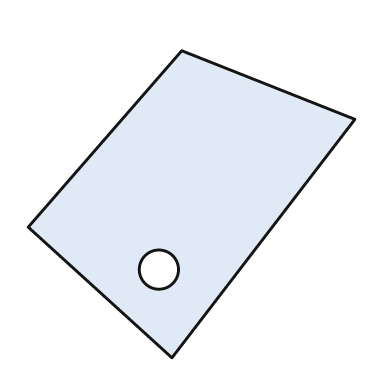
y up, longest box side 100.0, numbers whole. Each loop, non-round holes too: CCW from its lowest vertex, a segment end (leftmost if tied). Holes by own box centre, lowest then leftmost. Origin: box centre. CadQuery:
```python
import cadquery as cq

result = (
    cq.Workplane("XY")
    .moveTo(-6.0, -47.0)
    .lineTo(50.0, 26.0)
    .lineTo(-3.0, 47.0)
    .lineTo(-50.0, -7.0)
    .close()
    .moveTo(-10.0, -20.0)
    .circle(6.0)
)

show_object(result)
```